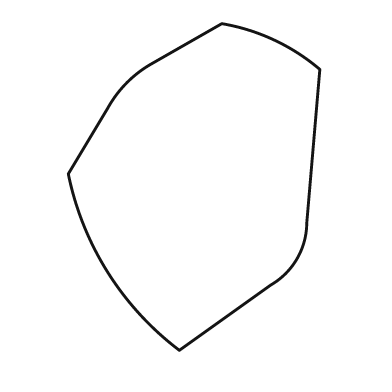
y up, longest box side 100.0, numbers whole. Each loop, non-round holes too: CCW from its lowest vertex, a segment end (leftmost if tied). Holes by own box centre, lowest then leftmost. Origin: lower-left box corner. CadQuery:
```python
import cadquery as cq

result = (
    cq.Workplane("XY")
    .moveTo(34.0, 0.0)
    .lineTo(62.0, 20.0)
    .threePointArc((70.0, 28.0), (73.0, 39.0))
    .lineTo(77.0, 86.0)
    .threePointArc((63.0, 95.0), (47.0, 100.0))
    .lineTo(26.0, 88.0)
    .threePointArc((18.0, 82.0), (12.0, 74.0))
    .lineTo(0.0, 54.0)
    .threePointArc((12.0, 24.0), (34.0, 0.0))
    .close()
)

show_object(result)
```